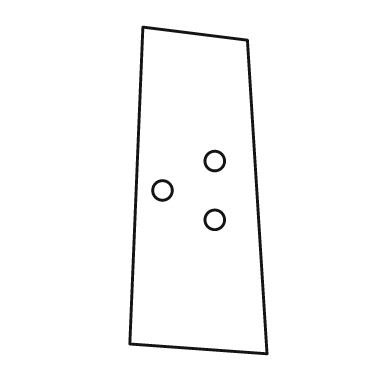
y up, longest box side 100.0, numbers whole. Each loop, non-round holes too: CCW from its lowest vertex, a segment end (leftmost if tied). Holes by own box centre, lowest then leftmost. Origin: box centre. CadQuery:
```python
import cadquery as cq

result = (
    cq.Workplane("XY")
    .moveTo(21.0, -50.0)
    .lineTo(15.0, 46.0)
    .lineTo(-17.0, 50.0)
    .lineTo(-21.0, -47.0)
    .close()
    .moveTo(5.0, -9.0)
    .circle(3.0)
    .moveTo(-11.0, 0.0)
    .circle(3.0)
    .moveTo(5.0, 9.0)
    .circle(3.0)
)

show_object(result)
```